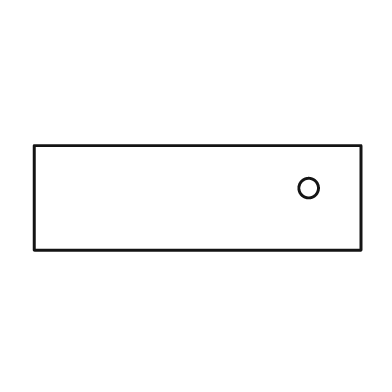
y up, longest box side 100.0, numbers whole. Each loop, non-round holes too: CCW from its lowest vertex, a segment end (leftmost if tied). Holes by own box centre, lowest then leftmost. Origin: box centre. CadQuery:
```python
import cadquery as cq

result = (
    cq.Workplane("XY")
    .moveTo(-50.0, -16.0)
    .lineTo(50.0, -16.0)
    .lineTo(50.0, 16.0)
    .lineTo(-50.0, 16.0)
    .close()
    .moveTo(34.0, 3.0)
    .circle(3.0)
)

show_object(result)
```